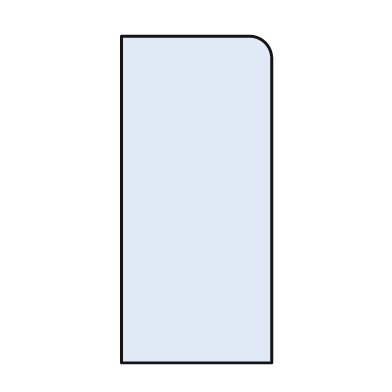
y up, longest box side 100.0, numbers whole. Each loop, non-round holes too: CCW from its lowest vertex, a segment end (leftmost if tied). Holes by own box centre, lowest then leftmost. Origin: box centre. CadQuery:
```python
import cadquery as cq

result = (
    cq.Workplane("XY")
    .moveTo(-23.0, -50.0)
    .lineTo(23.0, -50.0)
    .lineTo(23.0, 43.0)
    .threePointArc((21.0, 48.0), (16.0, 50.0))
    .lineTo(-23.0, 50.0)
    .close()
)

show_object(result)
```